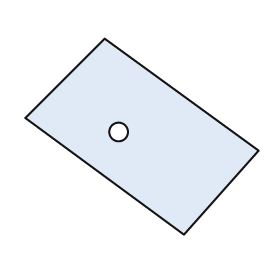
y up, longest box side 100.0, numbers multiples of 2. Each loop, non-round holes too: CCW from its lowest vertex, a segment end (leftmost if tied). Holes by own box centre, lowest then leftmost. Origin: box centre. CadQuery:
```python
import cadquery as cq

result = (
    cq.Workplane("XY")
    .moveTo(18.0, -42.0)
    .lineTo(50.0, -6.0)
    .lineTo(-16.0, 42.0)
    .lineTo(-50.0, 8.0)
    .close()
    .moveTo(-10.0, 2.0)
    .circle(4.0)
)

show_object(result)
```